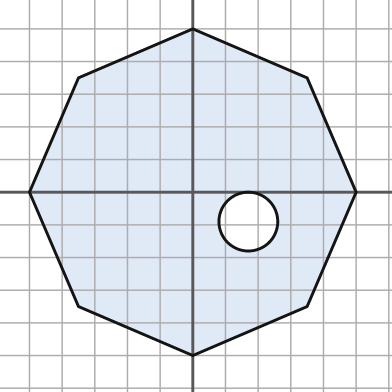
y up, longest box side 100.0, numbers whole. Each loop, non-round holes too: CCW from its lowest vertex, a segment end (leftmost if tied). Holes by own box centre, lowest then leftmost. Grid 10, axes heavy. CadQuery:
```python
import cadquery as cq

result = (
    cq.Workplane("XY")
    .moveTo(0.0, -50.0)
    .lineTo(35.0, -35.0)
    .lineTo(50.0, 0.0)
    .lineTo(35.0, 35.0)
    .lineTo(0.0, 50.0)
    .lineTo(-35.0, 35.0)
    .lineTo(-50.0, 0.0)
    .lineTo(-35.0, -35.0)
    .close()
    .moveTo(17.0, -9.0)
    .circle(9.0)
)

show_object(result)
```